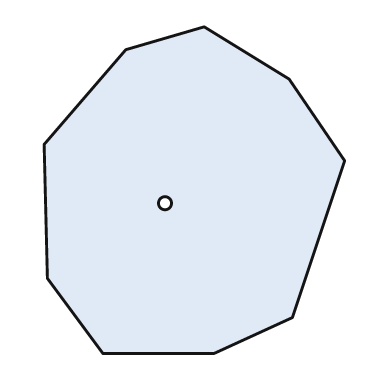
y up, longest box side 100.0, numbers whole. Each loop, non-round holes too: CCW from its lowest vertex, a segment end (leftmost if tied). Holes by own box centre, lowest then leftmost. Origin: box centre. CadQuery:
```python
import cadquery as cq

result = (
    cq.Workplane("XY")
    .moveTo(-28.0, -50.0)
    .lineTo(6.0, -50.0)
    .lineTo(30.0, -39.0)
    .lineTo(46.0, 9.0)
    .lineTo(29.0, 34.0)
    .lineTo(3.0, 50.0)
    .lineTo(-21.0, 43.0)
    .lineTo(-46.0, 14.0)
    .lineTo(-45.0, -27.0)
    .close()
    .moveTo(-9.0, -4.0)
    .circle(2.0)
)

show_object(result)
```